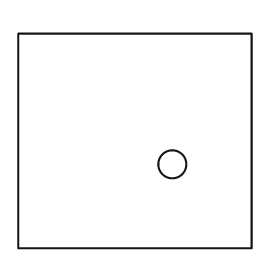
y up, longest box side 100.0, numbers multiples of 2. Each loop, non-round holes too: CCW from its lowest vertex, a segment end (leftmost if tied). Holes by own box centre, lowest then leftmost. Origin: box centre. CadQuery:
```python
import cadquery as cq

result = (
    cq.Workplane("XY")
    .moveTo(-50.0, -46.0)
    .lineTo(50.0, -46.0)
    .lineTo(50.0, 46.0)
    .lineTo(-50.0, 46.0)
    .close()
    .moveTo(16.0, -10.0)
    .circle(6.0)
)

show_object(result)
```